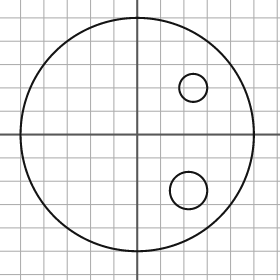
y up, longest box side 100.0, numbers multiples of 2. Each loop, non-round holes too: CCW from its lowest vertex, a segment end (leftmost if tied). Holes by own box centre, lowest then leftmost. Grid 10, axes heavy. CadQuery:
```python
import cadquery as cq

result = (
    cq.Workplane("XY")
    .moveTo(0.0, 0.0)
    .circle(50.0)
    .moveTo(22.0, -24.0)
    .circle(8.0)
    .moveTo(24.0, 20.0)
    .circle(6.0)
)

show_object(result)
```